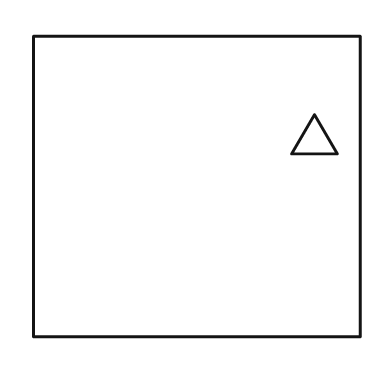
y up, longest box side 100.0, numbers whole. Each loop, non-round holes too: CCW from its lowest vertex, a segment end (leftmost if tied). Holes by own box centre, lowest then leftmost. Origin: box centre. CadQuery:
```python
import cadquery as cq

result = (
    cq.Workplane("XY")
    .moveTo(-50.0, -46.0)
    .lineTo(50.0, -46.0)
    .lineTo(50.0, 46.0)
    .lineTo(-50.0, 46.0)
    .close()
    .moveTo(29.0, 10.0)
    .lineTo(43.0, 10.0)
    .lineTo(36.0, 22.0)
    .close()
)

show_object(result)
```